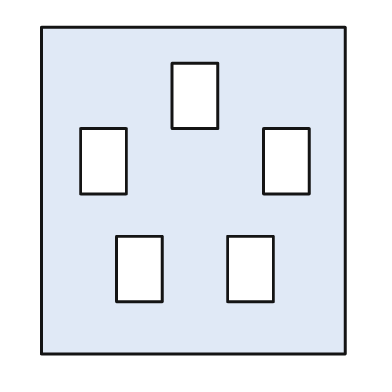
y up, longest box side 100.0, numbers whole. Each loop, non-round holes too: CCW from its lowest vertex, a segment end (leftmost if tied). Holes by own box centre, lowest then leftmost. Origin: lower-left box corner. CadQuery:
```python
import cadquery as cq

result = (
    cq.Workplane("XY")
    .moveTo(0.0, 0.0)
    .lineTo(93.0, 0.0)
    .lineTo(93.0, 100.0)
    .lineTo(0.0, 100.0)
    .close()
    .moveTo(23.0, 16.0)
    .lineTo(37.0, 16.0)
    .lineTo(37.0, 36.0)
    .lineTo(23.0, 36.0)
    .close()
    .moveTo(57.0, 16.0)
    .lineTo(71.0, 16.0)
    .lineTo(71.0, 36.0)
    .lineTo(57.0, 36.0)
    .close()
    .moveTo(12.0, 49.0)
    .lineTo(26.0, 49.0)
    .lineTo(26.0, 69.0)
    .lineTo(12.0, 69.0)
    .close()
    .moveTo(68.0, 49.0)
    .lineTo(82.0, 49.0)
    .lineTo(82.0, 69.0)
    .lineTo(68.0, 69.0)
    .close()
    .moveTo(40.0, 69.0)
    .lineTo(54.0, 69.0)
    .lineTo(54.0, 89.0)
    .lineTo(40.0, 89.0)
    .close()
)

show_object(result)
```